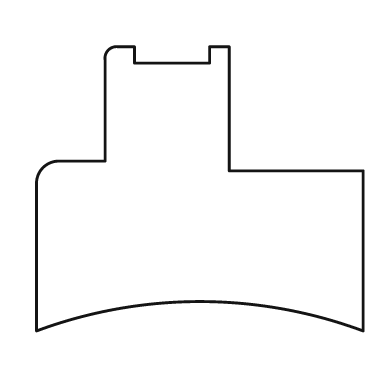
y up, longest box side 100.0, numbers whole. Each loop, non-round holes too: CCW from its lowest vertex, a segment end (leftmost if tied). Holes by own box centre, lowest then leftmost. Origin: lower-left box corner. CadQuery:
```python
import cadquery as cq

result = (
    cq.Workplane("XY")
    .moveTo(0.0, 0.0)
    .threePointArc((50.0, 9.0), (100.0, 0.0))
    .lineTo(100.0, 49.0)
    .lineTo(59.0, 49.0)
    .lineTo(59.0, 87.0)
    .lineTo(53.0, 87.0)
    .lineTo(53.0, 82.0)
    .lineTo(30.0, 82.0)
    .lineTo(30.0, 87.0)
    .lineTo(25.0, 87.0)
    .threePointArc((22.0, 86.0), (21.0, 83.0))
    .lineTo(21.0, 52.0)
    .lineTo(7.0, 52.0)
    .threePointArc((2.0, 50.0), (0.0, 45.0))
    .close()
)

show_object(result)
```